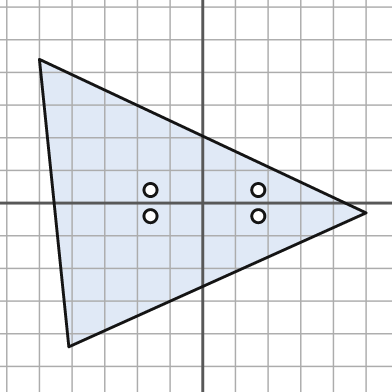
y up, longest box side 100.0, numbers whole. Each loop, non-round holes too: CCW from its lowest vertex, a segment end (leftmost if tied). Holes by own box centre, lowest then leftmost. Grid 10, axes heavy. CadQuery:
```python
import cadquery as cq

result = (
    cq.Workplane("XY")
    .moveTo(-41.0, -44.0)
    .lineTo(50.0, -3.0)
    .lineTo(-50.0, 44.0)
    .close()
    .moveTo(-16.0, -4.0)
    .circle(2.0)
    .moveTo(17.0, -4.0)
    .circle(2.0)
    .moveTo(-16.0, 4.0)
    .circle(2.0)
    .moveTo(17.0, 4.0)
    .circle(2.0)
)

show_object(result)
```